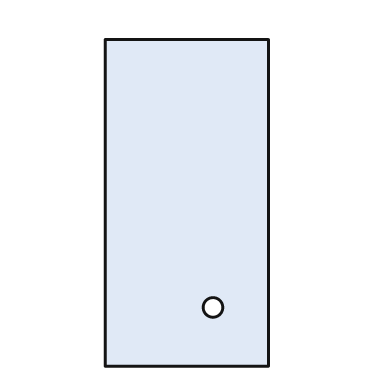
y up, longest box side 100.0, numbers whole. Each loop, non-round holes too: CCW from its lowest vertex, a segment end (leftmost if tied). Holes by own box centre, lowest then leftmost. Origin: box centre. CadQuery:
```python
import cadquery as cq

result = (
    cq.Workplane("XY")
    .moveTo(-25.0, -50.0)
    .lineTo(25.0, -50.0)
    .lineTo(25.0, 50.0)
    .lineTo(-25.0, 50.0)
    .close()
    .moveTo(8.0, -32.0)
    .circle(3.0)
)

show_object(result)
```